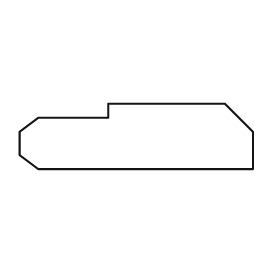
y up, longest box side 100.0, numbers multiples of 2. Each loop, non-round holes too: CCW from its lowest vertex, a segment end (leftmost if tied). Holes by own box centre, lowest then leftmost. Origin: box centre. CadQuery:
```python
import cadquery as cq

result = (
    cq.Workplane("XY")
    .moveTo(-42.0, -14.0)
    .lineTo(50.0, -14.0)
    .lineTo(50.0, 2.0)
    .lineTo(38.0, 14.0)
    .lineTo(-12.0, 14.0)
    .lineTo(-12.0, 8.0)
    .lineTo(-42.0, 8.0)
    .lineTo(-50.0, 2.0)
    .lineTo(-50.0, -8.0)
    .close()
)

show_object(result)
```